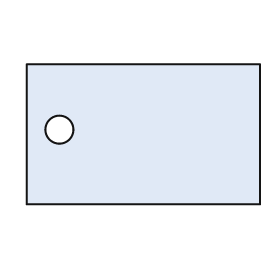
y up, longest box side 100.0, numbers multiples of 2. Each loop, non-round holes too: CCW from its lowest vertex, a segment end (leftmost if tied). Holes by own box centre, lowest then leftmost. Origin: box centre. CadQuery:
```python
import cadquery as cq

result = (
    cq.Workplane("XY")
    .moveTo(-50.0, -30.0)
    .lineTo(50.0, -30.0)
    .lineTo(50.0, 30.0)
    .lineTo(-50.0, 30.0)
    .close()
    .moveTo(-36.0, 2.0)
    .circle(6.0)
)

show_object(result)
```